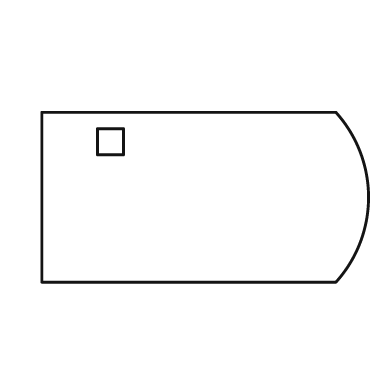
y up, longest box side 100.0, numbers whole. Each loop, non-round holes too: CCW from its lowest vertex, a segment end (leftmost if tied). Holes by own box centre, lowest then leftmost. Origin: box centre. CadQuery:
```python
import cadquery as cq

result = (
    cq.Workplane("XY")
    .moveTo(-50.0, -26.0)
    .lineTo(40.0, -26.0)
    .threePointArc((50.0, 0.0), (40.0, 26.0))
    .lineTo(-50.0, 26.0)
    .close()
    .moveTo(-33.0, 13.0)
    .lineTo(-25.0, 13.0)
    .lineTo(-25.0, 21.0)
    .lineTo(-33.0, 21.0)
    .close()
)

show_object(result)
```